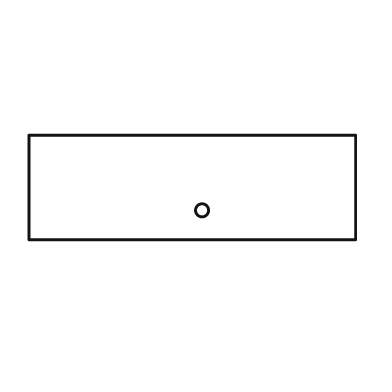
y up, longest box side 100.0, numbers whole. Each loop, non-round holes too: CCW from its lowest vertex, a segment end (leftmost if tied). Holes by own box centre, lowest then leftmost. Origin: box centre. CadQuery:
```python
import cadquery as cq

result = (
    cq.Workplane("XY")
    .moveTo(-50.0, -16.0)
    .lineTo(50.0, -16.0)
    .lineTo(50.0, 16.0)
    .lineTo(-50.0, 16.0)
    .close()
    .moveTo(3.0, -7.0)
    .circle(2.0)
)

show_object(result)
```